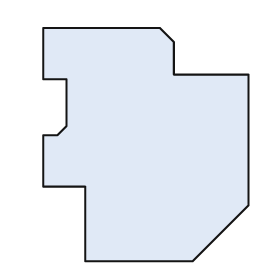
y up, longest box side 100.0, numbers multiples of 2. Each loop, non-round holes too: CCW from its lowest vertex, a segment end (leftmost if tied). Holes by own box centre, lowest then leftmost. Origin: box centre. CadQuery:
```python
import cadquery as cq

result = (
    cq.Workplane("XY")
    .moveTo(-26.0, -50.0)
    .lineTo(20.0, -50.0)
    .lineTo(44.0, -26.0)
    .lineTo(44.0, 30.0)
    .lineTo(12.0, 30.0)
    .lineTo(12.0, 44.0)
    .lineTo(6.0, 50.0)
    .lineTo(-44.0, 50.0)
    .lineTo(-44.0, 28.0)
    .lineTo(-34.0, 28.0)
    .lineTo(-34.0, 8.0)
    .lineTo(-38.0, 4.0)
    .lineTo(-44.0, 4.0)
    .lineTo(-44.0, -18.0)
    .lineTo(-26.0, -18.0)
    .close()
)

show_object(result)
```